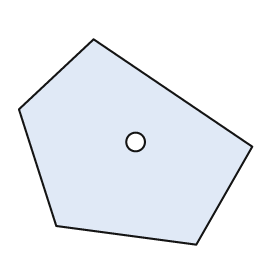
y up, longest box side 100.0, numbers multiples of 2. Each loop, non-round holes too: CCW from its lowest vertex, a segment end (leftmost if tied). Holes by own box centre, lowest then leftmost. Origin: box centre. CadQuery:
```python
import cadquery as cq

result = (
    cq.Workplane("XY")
    .moveTo(26.0, -44.0)
    .lineTo(50.0, -2.0)
    .lineTo(-18.0, 44.0)
    .lineTo(-50.0, 14.0)
    .lineTo(-34.0, -36.0)
    .close()
    .moveTo(0.0, 0.0)
    .circle(4.0)
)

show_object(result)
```